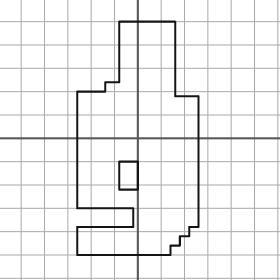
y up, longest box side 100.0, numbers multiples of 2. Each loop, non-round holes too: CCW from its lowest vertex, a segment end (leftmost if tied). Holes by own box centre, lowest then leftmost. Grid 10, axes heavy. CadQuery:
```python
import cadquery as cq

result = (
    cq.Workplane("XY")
    .moveTo(-26.0, -50.0)
    .lineTo(14.0, -50.0)
    .lineTo(14.0, -46.0)
    .lineTo(18.0, -46.0)
    .lineTo(18.0, -42.0)
    .lineTo(22.0, -42.0)
    .lineTo(22.0, -38.0)
    .lineTo(26.0, -38.0)
    .lineTo(26.0, 18.0)
    .lineTo(16.0, 18.0)
    .lineTo(16.0, 50.0)
    .lineTo(-8.0, 50.0)
    .lineTo(-8.0, 24.0)
    .lineTo(-14.0, 24.0)
    .lineTo(-14.0, 20.0)
    .lineTo(-26.0, 20.0)
    .lineTo(-26.0, -30.0)
    .lineTo(-2.0, -30.0)
    .lineTo(-2.0, -38.0)
    .lineTo(-26.0, -38.0)
    .close()
    .moveTo(-8.0, -22.0)
    .lineTo(0.0, -22.0)
    .lineTo(0.0, -10.0)
    .lineTo(-8.0, -10.0)
    .close()
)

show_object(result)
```